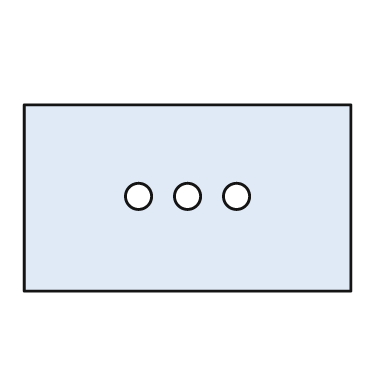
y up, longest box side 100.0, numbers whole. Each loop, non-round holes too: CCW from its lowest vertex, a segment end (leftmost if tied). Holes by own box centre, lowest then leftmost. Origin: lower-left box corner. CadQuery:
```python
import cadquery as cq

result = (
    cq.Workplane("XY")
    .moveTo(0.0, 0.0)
    .lineTo(100.0, 0.0)
    .lineTo(100.0, 57.0)
    .lineTo(0.0, 57.0)
    .close()
    .moveTo(35.0, 29.0)
    .circle(4.0)
    .moveTo(50.0, 29.0)
    .circle(4.0)
    .moveTo(65.0, 29.0)
    .circle(4.0)
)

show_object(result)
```